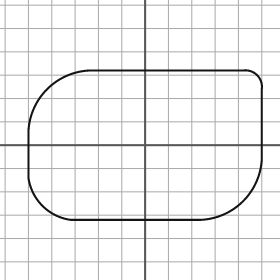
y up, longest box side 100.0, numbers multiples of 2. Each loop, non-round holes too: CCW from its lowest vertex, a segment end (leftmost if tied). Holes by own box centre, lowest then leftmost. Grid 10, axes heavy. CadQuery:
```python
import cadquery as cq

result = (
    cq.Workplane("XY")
    .moveTo(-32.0, -32.0)
    .lineTo(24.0, -32.0)
    .threePointArc((42.0, -24.0), (50.0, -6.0))
    .lineTo(50.0, 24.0)
    .threePointArc((48.0, 30.0), (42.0, 32.0))
    .lineTo(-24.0, 32.0)
    .threePointArc((-42.0, 24.0), (-50.0, 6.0))
    .lineTo(-50.0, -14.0)
    .threePointArc((-44.0, -26.0), (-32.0, -32.0))
    .close()
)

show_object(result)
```